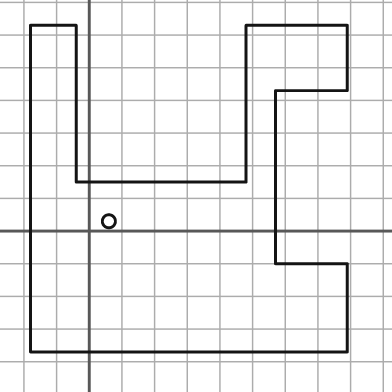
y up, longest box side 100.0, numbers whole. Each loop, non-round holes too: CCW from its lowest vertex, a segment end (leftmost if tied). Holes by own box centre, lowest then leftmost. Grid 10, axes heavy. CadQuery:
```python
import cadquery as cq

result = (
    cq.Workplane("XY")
    .moveTo(-18.0, -37.0)
    .lineTo(79.0, -37.0)
    .lineTo(79.0, -10.0)
    .lineTo(57.0, -10.0)
    .lineTo(57.0, 43.0)
    .lineTo(79.0, 43.0)
    .lineTo(79.0, 63.0)
    .lineTo(48.0, 63.0)
    .lineTo(48.0, 15.0)
    .lineTo(-4.0, 15.0)
    .lineTo(-4.0, 63.0)
    .lineTo(-18.0, 63.0)
    .close()
    .moveTo(6.0, 3.0)
    .circle(2.0)
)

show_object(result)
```